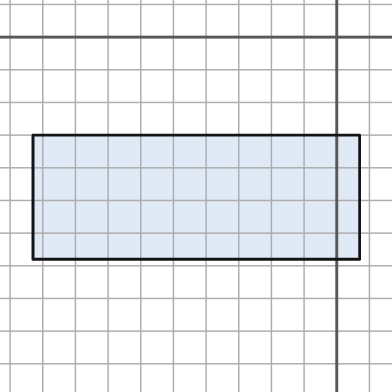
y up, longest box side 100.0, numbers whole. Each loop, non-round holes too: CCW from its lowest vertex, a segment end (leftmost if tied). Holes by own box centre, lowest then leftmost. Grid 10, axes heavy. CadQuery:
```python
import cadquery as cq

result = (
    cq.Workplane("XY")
    .moveTo(-93.0, -68.0)
    .lineTo(7.0, -68.0)
    .lineTo(7.0, -30.0)
    .lineTo(-93.0, -30.0)
    .close()
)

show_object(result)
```